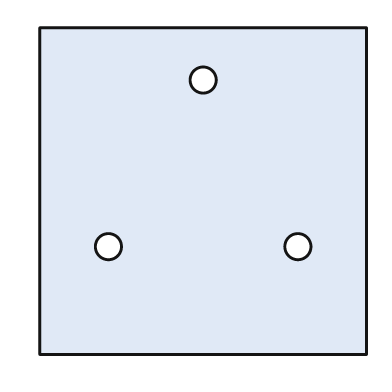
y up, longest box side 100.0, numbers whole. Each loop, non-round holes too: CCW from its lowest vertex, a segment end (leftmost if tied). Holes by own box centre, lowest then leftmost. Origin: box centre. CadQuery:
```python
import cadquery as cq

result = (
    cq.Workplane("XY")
    .moveTo(-50.0, -50.0)
    .lineTo(50.0, -50.0)
    .lineTo(50.0, 50.0)
    .lineTo(-50.0, 50.0)
    .close()
    .moveTo(-29.0, -17.0)
    .circle(4.0)
    .moveTo(29.0, -17.0)
    .circle(4.0)
    .moveTo(0.0, 34.0)
    .circle(4.0)
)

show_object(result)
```